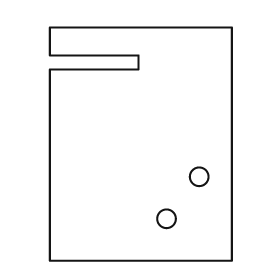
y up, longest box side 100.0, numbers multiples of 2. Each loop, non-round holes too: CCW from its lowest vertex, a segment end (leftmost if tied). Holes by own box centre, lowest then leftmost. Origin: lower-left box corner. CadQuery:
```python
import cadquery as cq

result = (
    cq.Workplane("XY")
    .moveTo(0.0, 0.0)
    .lineTo(78.0, 0.0)
    .lineTo(78.0, 100.0)
    .lineTo(0.0, 100.0)
    .lineTo(0.0, 88.0)
    .lineTo(38.0, 88.0)
    .lineTo(38.0, 82.0)
    .lineTo(0.0, 82.0)
    .close()
    .moveTo(50.0, 18.0)
    .circle(4.0)
    .moveTo(64.0, 36.0)
    .circle(4.0)
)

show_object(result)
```